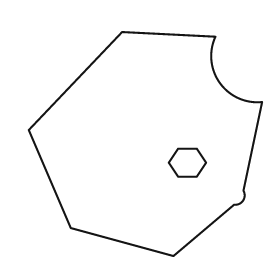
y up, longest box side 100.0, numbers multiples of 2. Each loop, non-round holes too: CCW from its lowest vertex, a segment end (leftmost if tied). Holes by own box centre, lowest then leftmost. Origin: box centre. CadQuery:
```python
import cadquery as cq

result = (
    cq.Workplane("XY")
    .moveTo(12.0, -48.0)
    .lineTo(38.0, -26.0)
    .threePointArc((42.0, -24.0), (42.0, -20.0))
    .lineTo(50.0, 18.0)
    .threePointArc((32.0, 26.0), (30.0, 46.0))
    .lineTo(-10.0, 48.0)
    .lineTo(-50.0, 6.0)
    .lineTo(-32.0, -36.0)
    .close()
    .moveTo(14.0, -14.0)
    .lineTo(22.0, -14.0)
    .lineTo(26.0, -8.0)
    .lineTo(22.0, -2.0)
    .lineTo(14.0, -2.0)
    .lineTo(10.0, -8.0)
    .close()
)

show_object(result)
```